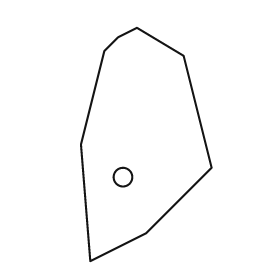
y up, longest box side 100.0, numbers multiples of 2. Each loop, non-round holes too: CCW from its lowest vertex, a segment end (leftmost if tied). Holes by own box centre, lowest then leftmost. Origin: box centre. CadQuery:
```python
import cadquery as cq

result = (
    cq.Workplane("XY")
    .moveTo(-24.0, -50.0)
    .lineTo(0.0, -38.0)
    .lineTo(28.0, -10.0)
    .lineTo(16.0, 38.0)
    .lineTo(-4.0, 50.0)
    .lineTo(-12.0, 46.0)
    .lineTo(-18.0, 40.0)
    .lineTo(-28.0, 0.0)
    .close()
    .moveTo(-10.0, -14.0)
    .circle(4.0)
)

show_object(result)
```